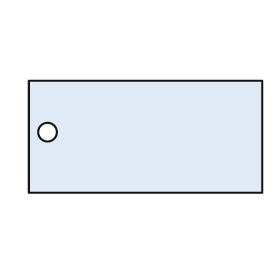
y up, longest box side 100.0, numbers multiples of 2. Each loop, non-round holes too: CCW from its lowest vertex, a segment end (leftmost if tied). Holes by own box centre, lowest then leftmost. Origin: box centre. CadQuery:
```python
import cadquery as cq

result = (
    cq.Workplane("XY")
    .moveTo(-50.0, -24.0)
    .lineTo(50.0, -24.0)
    .lineTo(50.0, 24.0)
    .lineTo(-50.0, 24.0)
    .close()
    .moveTo(-42.0, 2.0)
    .circle(4.0)
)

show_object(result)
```